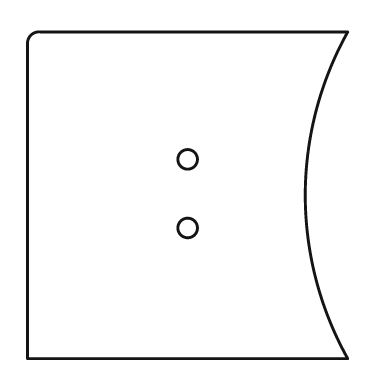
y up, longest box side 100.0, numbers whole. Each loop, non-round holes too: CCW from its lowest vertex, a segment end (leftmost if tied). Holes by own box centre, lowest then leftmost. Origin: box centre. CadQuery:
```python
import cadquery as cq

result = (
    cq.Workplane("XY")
    .moveTo(-49.0, -50.0)
    .lineTo(49.0, -50.0)
    .threePointArc((36.0, 0.0), (49.0, 50.0))
    .lineTo(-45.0, 50.0)
    .threePointArc((-48.0, 49.0), (-49.0, 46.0))
    .close()
    .moveTo(0.0, -10.0)
    .circle(3.0)
    .moveTo(0.0, 11.0)
    .circle(3.0)
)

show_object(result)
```